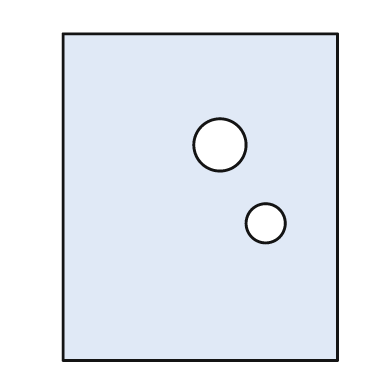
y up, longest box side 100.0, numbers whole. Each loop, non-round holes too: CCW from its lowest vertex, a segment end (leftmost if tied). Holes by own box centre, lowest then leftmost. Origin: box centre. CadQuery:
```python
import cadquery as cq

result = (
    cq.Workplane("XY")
    .moveTo(-42.0, -50.0)
    .lineTo(42.0, -50.0)
    .lineTo(42.0, 50.0)
    .lineTo(-42.0, 50.0)
    .close()
    .moveTo(20.0, -8.0)
    .circle(6.0)
    .moveTo(6.0, 16.0)
    .circle(8.0)
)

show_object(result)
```